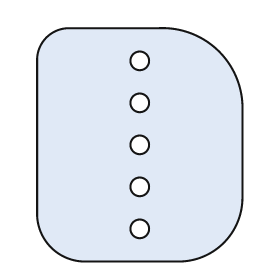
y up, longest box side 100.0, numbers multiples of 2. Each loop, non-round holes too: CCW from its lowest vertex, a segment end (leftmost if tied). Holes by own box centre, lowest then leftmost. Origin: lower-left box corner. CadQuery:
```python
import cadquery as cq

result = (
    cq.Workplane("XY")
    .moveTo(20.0, 0.0)
    .lineTo(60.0, 0.0)
    .threePointArc((80.0, 8.0), (88.0, 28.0))
    .lineTo(88.0, 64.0)
    .threePointArc((78.0, 90.0), (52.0, 100.0))
    .lineTo(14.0, 100.0)
    .threePointArc((4.0, 96.0), (0.0, 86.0))
    .lineTo(0.0, 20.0)
    .threePointArc((6.0, 6.0), (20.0, 0.0))
    .close()
    .moveTo(44.0, 14.0)
    .circle(4.0)
    .moveTo(44.0, 32.0)
    .circle(4.0)
    .moveTo(44.0, 50.0)
    .circle(4.0)
    .moveTo(44.0, 68.0)
    .circle(4.0)
    .moveTo(44.0, 86.0)
    .circle(4.0)
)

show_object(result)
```